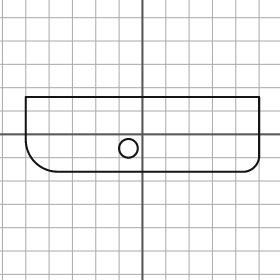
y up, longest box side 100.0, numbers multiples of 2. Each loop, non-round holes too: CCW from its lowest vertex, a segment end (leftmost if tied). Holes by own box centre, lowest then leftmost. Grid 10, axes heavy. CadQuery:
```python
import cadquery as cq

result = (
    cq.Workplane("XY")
    .moveTo(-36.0, -16.0)
    .lineTo(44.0, -16.0)
    .threePointArc((48.0, -14.0), (50.0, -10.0))
    .lineTo(50.0, 16.0)
    .lineTo(-50.0, 16.0)
    .lineTo(-50.0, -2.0)
    .threePointArc((-46.0, -12.0), (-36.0, -16.0))
    .close()
    .moveTo(-6.0, -6.0)
    .circle(4.0)
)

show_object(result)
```